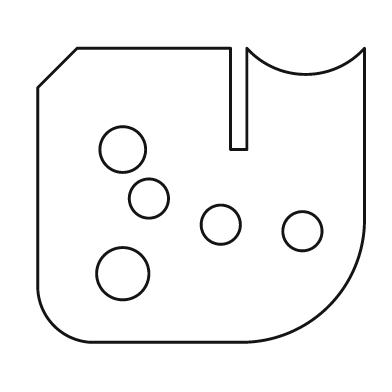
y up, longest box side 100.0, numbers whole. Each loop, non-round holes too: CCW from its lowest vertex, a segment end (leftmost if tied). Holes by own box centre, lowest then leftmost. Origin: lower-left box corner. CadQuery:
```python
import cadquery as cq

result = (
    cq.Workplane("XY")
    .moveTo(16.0, 0.0)
    .lineTo(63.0, 0.0)
    .threePointArc((89.0, 11.0), (100.0, 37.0))
    .lineTo(100.0, 90.0)
    .threePointArc((82.0, 82.0), (64.0, 90.0))
    .lineTo(64.0, 59.0)
    .lineTo(59.0, 59.0)
    .lineTo(59.0, 90.0)
    .lineTo(12.0, 90.0)
    .lineTo(0.0, 78.0)
    .lineTo(0.0, 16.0)
    .threePointArc((5.0, 5.0), (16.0, 0.0))
    .close()
    .moveTo(26.0, 21.0)
    .circle(8.0)
    .moveTo(81.0, 34.0)
    .circle(6.0)
    .moveTo(56.0, 36.0)
    .circle(6.0)
    .moveTo(34.0, 44.0)
    .circle(6.0)
    .moveTo(26.0, 59.0)
    .circle(7.0)
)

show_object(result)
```